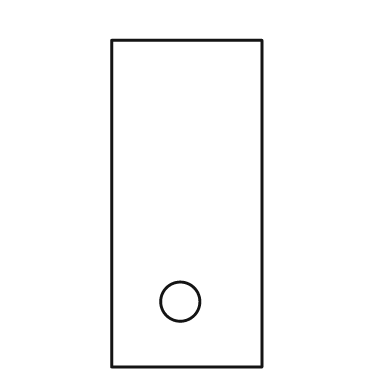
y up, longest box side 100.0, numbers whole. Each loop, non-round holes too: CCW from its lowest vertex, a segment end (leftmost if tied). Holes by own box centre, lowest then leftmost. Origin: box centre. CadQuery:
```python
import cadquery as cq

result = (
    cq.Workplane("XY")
    .moveTo(-23.0, -50.0)
    .lineTo(23.0, -50.0)
    .lineTo(23.0, 50.0)
    .lineTo(-23.0, 50.0)
    .close()
    .moveTo(-2.0, -30.0)
    .circle(6.0)
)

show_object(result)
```